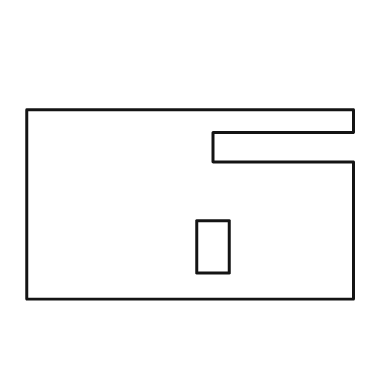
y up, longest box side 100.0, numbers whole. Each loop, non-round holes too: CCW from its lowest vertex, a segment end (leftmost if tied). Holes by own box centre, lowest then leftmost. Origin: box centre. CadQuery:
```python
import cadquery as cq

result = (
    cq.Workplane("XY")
    .moveTo(-50.0, -29.0)
    .lineTo(50.0, -29.0)
    .lineTo(50.0, 13.0)
    .lineTo(7.0, 13.0)
    .lineTo(7.0, 22.0)
    .lineTo(50.0, 22.0)
    .lineTo(50.0, 29.0)
    .lineTo(-50.0, 29.0)
    .close()
    .moveTo(2.0, -21.0)
    .lineTo(12.0, -21.0)
    .lineTo(12.0, -5.0)
    .lineTo(2.0, -5.0)
    .close()
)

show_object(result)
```